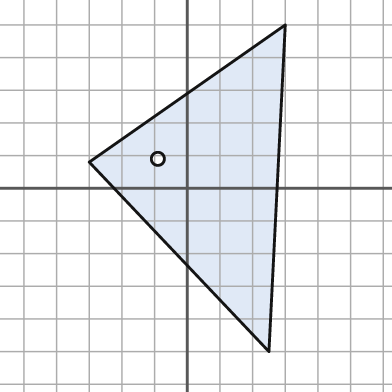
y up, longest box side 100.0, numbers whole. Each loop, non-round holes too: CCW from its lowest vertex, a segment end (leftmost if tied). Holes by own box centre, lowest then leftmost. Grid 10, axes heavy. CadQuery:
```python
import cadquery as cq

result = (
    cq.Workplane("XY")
    .moveTo(25.0, -50.0)
    .lineTo(30.0, 50.0)
    .lineTo(-30.0, 8.0)
    .close()
    .moveTo(-9.0, 9.0)
    .circle(2.0)
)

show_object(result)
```